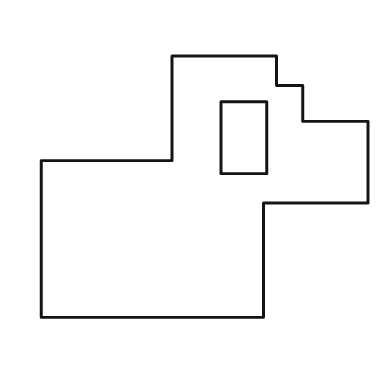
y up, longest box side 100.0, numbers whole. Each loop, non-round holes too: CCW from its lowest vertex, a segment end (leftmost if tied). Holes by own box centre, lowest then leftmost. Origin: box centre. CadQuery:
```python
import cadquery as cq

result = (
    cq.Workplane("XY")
    .moveTo(-50.0, -40.0)
    .lineTo(18.0, -40.0)
    .lineTo(18.0, -5.0)
    .lineTo(50.0, -5.0)
    .lineTo(50.0, 20.0)
    .lineTo(30.0, 20.0)
    .lineTo(30.0, 31.0)
    .lineTo(22.0, 31.0)
    .lineTo(22.0, 40.0)
    .lineTo(-10.0, 40.0)
    .lineTo(-10.0, 8.0)
    .lineTo(-50.0, 8.0)
    .close()
    .moveTo(5.0, 4.0)
    .lineTo(19.0, 4.0)
    .lineTo(19.0, 26.0)
    .lineTo(5.0, 26.0)
    .close()
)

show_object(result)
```